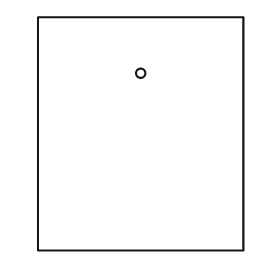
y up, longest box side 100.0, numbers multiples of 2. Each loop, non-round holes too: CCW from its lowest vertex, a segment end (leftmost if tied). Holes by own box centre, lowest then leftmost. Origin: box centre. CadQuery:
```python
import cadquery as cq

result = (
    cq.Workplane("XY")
    .moveTo(-44.0, -50.0)
    .lineTo(44.0, -50.0)
    .lineTo(44.0, 50.0)
    .lineTo(-44.0, 50.0)
    .close()
    .moveTo(0.0, 26.0)
    .circle(2.0)
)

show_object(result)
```